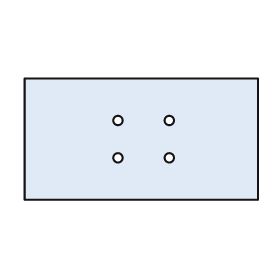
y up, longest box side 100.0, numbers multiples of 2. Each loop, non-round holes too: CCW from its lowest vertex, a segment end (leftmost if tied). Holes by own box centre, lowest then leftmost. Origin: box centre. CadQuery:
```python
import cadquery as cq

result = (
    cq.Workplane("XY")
    .moveTo(-50.0, -26.0)
    .lineTo(50.0, -26.0)
    .lineTo(50.0, 26.0)
    .lineTo(-50.0, 26.0)
    .close()
    .moveTo(-10.0, -8.0)
    .circle(2.0)
    .moveTo(12.0, -8.0)
    .circle(2.0)
    .moveTo(-10.0, 8.0)
    .circle(2.0)
    .moveTo(12.0, 8.0)
    .circle(2.0)
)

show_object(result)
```